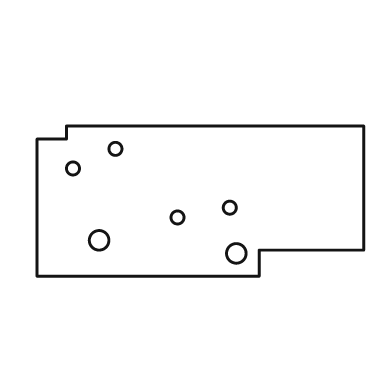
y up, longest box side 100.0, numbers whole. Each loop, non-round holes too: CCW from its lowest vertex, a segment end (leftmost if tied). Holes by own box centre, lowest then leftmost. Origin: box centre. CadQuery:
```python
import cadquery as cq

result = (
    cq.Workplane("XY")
    .moveTo(-50.0, -23.0)
    .lineTo(18.0, -23.0)
    .lineTo(18.0, -15.0)
    .lineTo(50.0, -15.0)
    .lineTo(50.0, 23.0)
    .lineTo(-41.0, 23.0)
    .lineTo(-41.0, 19.0)
    .lineTo(-50.0, 19.0)
    .close()
    .moveTo(11.0, -16.0)
    .circle(3.0)
    .moveTo(-31.0, -12.0)
    .circle(3.0)
    .moveTo(-7.0, -5.0)
    .circle(2.0)
    .moveTo(9.0, -2.0)
    .circle(2.0)
    .moveTo(-39.0, 10.0)
    .circle(2.0)
    .moveTo(-26.0, 16.0)
    .circle(2.0)
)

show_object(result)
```